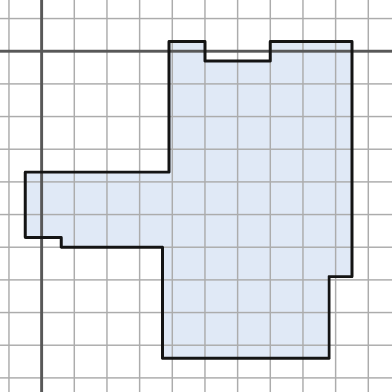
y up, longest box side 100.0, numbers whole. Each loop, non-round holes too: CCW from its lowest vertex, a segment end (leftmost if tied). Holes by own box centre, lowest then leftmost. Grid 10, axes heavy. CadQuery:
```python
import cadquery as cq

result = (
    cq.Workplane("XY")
    .moveTo(37.0, -94.0)
    .lineTo(88.0, -94.0)
    .lineTo(88.0, -69.0)
    .lineTo(95.0, -69.0)
    .lineTo(95.0, 3.0)
    .lineTo(70.0, 3.0)
    .lineTo(70.0, -3.0)
    .lineTo(50.0, -3.0)
    .lineTo(50.0, 3.0)
    .lineTo(39.0, 3.0)
    .lineTo(39.0, -37.0)
    .lineTo(-5.0, -37.0)
    .lineTo(-5.0, -57.0)
    .lineTo(6.0, -57.0)
    .lineTo(6.0, -60.0)
    .lineTo(37.0, -60.0)
    .close()
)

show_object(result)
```